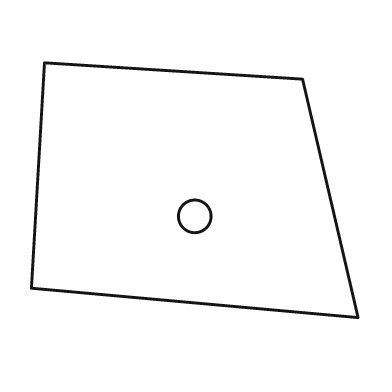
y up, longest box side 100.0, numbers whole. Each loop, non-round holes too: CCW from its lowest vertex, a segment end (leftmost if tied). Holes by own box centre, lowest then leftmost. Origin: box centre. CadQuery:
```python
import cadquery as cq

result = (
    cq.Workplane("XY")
    .moveTo(50.0, -39.0)
    .lineTo(33.0, 34.0)
    .lineTo(-46.0, 39.0)
    .lineTo(-50.0, -30.0)
    .close()
    .moveTo(0.0, -8.0)
    .circle(5.0)
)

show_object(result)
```